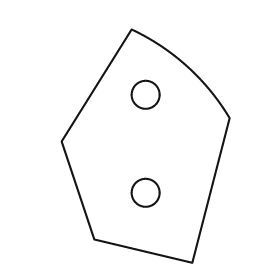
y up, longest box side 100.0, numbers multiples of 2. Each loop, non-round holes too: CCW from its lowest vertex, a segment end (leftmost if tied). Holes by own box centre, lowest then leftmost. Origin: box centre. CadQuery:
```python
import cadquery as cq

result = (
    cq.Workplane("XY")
    .moveTo(20.0, -50.0)
    .lineTo(36.0, 12.0)
    .threePointArc((18.0, 34.0), (-6.0, 50.0))
    .lineTo(-36.0, 2.0)
    .lineTo(-22.0, -40.0)
    .close()
    .moveTo(0.0, -20.0)
    .circle(6.0)
    .moveTo(0.0, 22.0)
    .circle(6.0)
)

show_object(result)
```